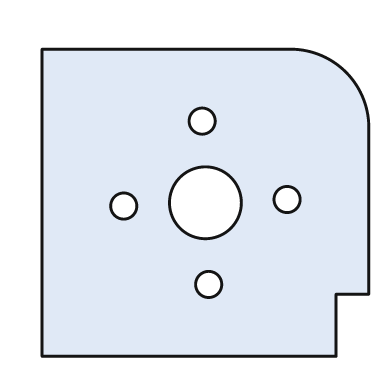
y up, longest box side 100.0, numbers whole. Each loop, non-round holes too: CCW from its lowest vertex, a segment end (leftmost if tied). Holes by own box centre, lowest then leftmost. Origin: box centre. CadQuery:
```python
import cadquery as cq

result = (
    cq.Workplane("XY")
    .moveTo(-50.0, -47.0)
    .lineTo(40.0, -47.0)
    .lineTo(40.0, -28.0)
    .lineTo(50.0, -28.0)
    .lineTo(50.0, 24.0)
    .threePointArc((43.0, 40.0), (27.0, 47.0))
    .lineTo(-50.0, 47.0)
    .close()
    .moveTo(1.0, -25.0)
    .circle(4.0)
    .moveTo(-25.0, -1.0)
    .circle(4.0)
    .moveTo(0.0, 0.0)
    .circle(11.0)
    .moveTo(25.0, 1.0)
    .circle(4.0)
    .moveTo(-1.0, 25.0)
    .circle(4.0)
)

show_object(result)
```